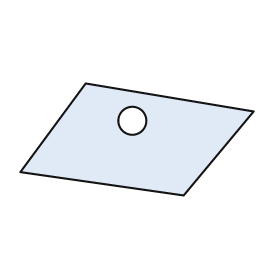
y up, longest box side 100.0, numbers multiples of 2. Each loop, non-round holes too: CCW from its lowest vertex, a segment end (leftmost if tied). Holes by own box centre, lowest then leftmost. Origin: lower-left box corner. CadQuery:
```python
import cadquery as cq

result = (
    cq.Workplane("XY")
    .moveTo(70.0, 0.0)
    .lineTo(100.0, 36.0)
    .lineTo(28.0, 48.0)
    .lineTo(0.0, 10.0)
    .close()
    .moveTo(48.0, 32.0)
    .circle(6.0)
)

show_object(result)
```